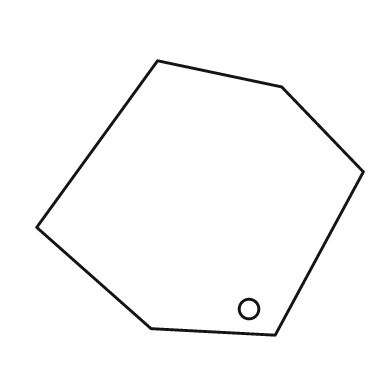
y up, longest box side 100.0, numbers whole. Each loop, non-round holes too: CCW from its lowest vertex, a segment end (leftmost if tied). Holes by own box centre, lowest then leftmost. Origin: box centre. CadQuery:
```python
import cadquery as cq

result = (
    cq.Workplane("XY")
    .moveTo(23.0, -42.0)
    .lineTo(50.0, 8.0)
    .lineTo(25.0, 34.0)
    .lineTo(-13.0, 42.0)
    .lineTo(-50.0, -9.0)
    .lineTo(-15.0, -40.0)
    .close()
    .moveTo(15.0, -34.0)
    .circle(3.0)
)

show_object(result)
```